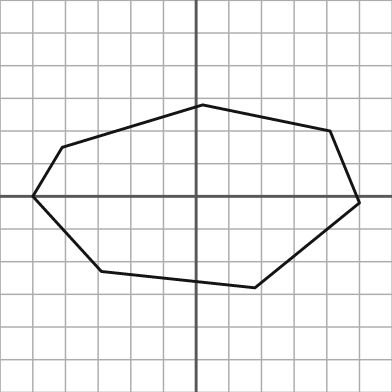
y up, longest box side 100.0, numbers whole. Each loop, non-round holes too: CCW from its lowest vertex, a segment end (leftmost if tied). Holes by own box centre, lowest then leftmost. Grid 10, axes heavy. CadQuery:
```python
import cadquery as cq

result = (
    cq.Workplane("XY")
    .moveTo(18.0, -28.0)
    .lineTo(50.0, -2.0)
    .lineTo(41.0, 20.0)
    .lineTo(2.0, 28.0)
    .lineTo(-41.0, 15.0)
    .lineTo(-50.0, 0.0)
    .lineTo(-29.0, -23.0)
    .close()
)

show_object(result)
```